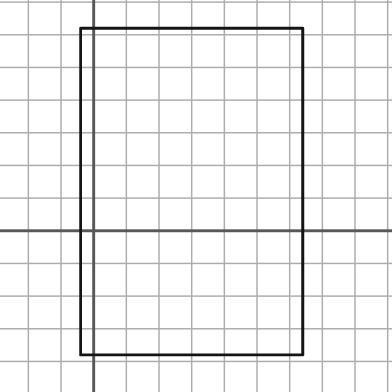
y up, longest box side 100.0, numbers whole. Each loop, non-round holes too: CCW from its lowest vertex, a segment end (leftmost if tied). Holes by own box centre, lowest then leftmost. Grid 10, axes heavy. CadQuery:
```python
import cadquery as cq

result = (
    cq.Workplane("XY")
    .moveTo(-4.0, -38.0)
    .lineTo(64.0, -38.0)
    .lineTo(64.0, 62.0)
    .lineTo(-4.0, 62.0)
    .close()
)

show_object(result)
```